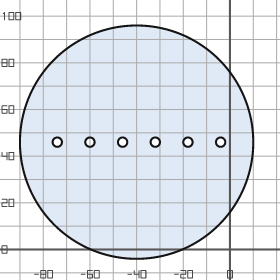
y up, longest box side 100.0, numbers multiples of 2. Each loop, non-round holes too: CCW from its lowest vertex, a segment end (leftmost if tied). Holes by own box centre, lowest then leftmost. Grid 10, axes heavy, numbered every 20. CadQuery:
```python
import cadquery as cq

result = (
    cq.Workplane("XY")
    .moveTo(-40.0, 46.0)
    .circle(50.0)
    .moveTo(-74.0, 46.0)
    .circle(2.0)
    .moveTo(-60.0, 46.0)
    .circle(2.0)
    .moveTo(-46.0, 46.0)
    .circle(2.0)
    .moveTo(-32.0, 46.0)
    .circle(2.0)
    .moveTo(-18.0, 46.0)
    .circle(2.0)
    .moveTo(-4.0, 46.0)
    .circle(2.0)
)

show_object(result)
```